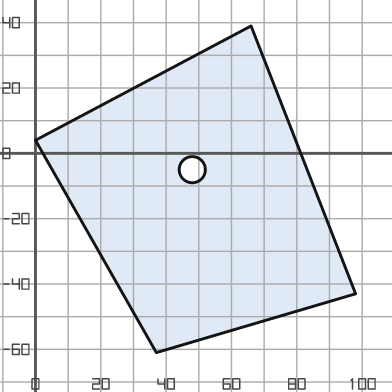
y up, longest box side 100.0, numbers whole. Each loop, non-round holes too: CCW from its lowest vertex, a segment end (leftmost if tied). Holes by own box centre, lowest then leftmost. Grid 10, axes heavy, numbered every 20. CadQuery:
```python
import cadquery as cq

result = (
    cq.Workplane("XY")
    .moveTo(37.0, -61.0)
    .lineTo(98.0, -43.0)
    .lineTo(66.0, 39.0)
    .lineTo(0.0, 4.0)
    .close()
    .moveTo(48.0, -5.0)
    .circle(4.0)
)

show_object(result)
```